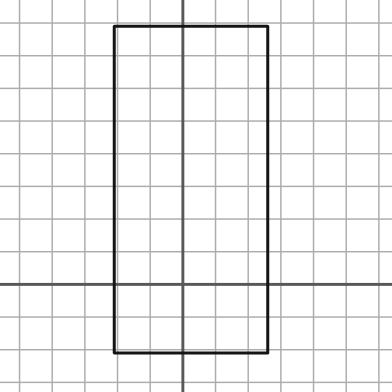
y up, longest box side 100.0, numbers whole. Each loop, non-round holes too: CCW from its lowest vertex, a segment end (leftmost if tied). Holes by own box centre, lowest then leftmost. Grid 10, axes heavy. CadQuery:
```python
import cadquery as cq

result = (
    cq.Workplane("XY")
    .moveTo(-21.0, -21.0)
    .lineTo(26.0, -21.0)
    .lineTo(26.0, 79.0)
    .lineTo(-21.0, 79.0)
    .close()
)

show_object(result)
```